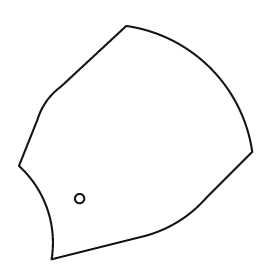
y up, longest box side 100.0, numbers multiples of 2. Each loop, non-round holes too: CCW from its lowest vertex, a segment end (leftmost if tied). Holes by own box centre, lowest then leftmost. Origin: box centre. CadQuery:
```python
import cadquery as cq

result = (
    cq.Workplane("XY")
    .moveTo(-36.0, -50.0)
    .lineTo(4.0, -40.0)
    .threePointArc((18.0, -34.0), (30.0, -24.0))
    .lineTo(50.0, -4.0)
    .threePointArc((32.0, 32.0), (-4.0, 50.0))
    .lineTo(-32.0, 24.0)
    .threePointArc((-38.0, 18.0), (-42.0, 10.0))
    .lineTo(-50.0, -10.0)
    .threePointArc((-38.0, -28.0), (-36.0, -50.0))
    .close()
    .moveTo(-24.0, -24.0)
    .circle(2.0)
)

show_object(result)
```